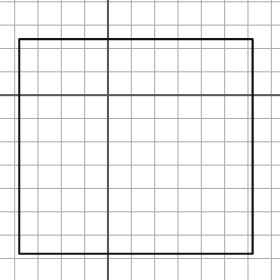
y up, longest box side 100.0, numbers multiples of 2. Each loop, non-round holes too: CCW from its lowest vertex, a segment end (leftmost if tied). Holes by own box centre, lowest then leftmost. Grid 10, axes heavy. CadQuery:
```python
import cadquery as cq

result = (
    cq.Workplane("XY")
    .moveTo(-38.0, -68.0)
    .lineTo(62.0, -68.0)
    .lineTo(62.0, 24.0)
    .lineTo(-38.0, 24.0)
    .close()
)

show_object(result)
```